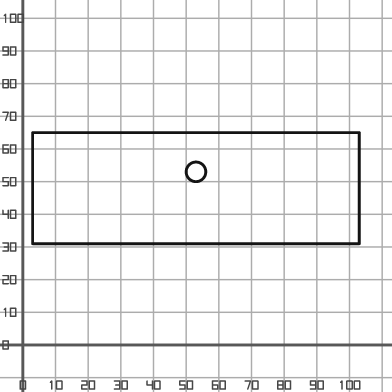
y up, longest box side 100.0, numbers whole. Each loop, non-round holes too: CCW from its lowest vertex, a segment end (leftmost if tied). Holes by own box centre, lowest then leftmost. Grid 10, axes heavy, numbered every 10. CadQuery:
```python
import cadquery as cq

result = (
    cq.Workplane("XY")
    .moveTo(3.0, 31.0)
    .lineTo(103.0, 31.0)
    .lineTo(103.0, 65.0)
    .lineTo(3.0, 65.0)
    .close()
    .moveTo(53.0, 53.0)
    .circle(3.0)
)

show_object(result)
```